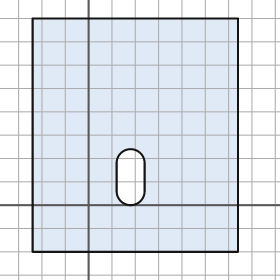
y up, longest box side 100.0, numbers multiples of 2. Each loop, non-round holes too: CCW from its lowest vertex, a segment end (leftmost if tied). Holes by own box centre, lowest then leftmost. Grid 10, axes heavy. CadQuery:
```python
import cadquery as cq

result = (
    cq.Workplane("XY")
    .moveTo(-24.0, -20.0)
    .lineTo(64.0, -20.0)
    .lineTo(64.0, 80.0)
    .lineTo(-24.0, 80.0)
    .close()
    .moveTo(12.0, 6.0)
    .threePointArc((18.0, 0.0), (24.0, 6.0))
    .lineTo(24.0, 18.0)
    .threePointArc((18.0, 24.0), (12.0, 18.0))
    .close()
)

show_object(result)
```